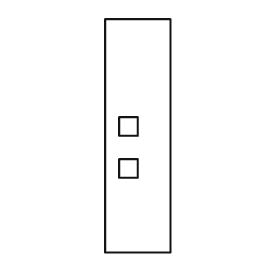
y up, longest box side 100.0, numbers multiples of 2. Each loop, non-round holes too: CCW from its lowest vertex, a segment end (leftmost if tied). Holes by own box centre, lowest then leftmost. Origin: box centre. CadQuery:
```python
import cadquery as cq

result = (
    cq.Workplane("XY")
    .moveTo(-14.0, -50.0)
    .lineTo(14.0, -50.0)
    .lineTo(14.0, 50.0)
    .lineTo(-14.0, 50.0)
    .close()
    .moveTo(-8.0, -18.0)
    .lineTo(0.0, -18.0)
    .lineTo(0.0, -10.0)
    .lineTo(-8.0, -10.0)
    .close()
    .moveTo(-8.0, 0.0)
    .lineTo(0.0, 0.0)
    .lineTo(0.0, 8.0)
    .lineTo(-8.0, 8.0)
    .close()
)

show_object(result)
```